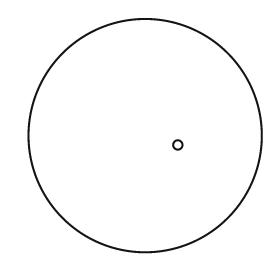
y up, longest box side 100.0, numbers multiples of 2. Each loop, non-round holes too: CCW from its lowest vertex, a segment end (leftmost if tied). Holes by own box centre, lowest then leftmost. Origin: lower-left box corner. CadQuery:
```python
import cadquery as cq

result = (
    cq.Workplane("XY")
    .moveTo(50.0, 50.0)
    .circle(50.0)
    .moveTo(64.0, 46.0)
    .circle(2.0)
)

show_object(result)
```